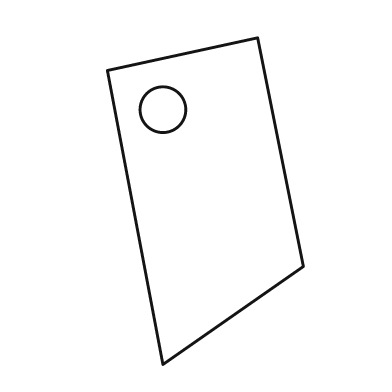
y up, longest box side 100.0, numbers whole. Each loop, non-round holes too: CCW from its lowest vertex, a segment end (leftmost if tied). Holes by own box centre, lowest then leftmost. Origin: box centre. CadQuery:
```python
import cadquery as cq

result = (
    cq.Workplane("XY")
    .moveTo(-13.0, -50.0)
    .lineTo(30.0, -20.0)
    .lineTo(16.0, 50.0)
    .lineTo(-30.0, 40.0)
    .close()
    .moveTo(-13.0, 28.0)
    .circle(7.0)
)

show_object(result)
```